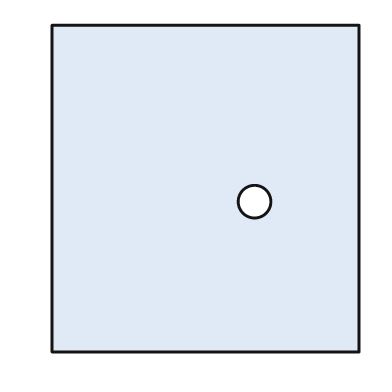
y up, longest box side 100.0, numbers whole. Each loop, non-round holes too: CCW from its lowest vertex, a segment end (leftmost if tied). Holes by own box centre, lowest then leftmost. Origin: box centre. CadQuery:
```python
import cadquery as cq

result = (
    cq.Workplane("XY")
    .moveTo(-47.0, -50.0)
    .lineTo(47.0, -50.0)
    .lineTo(47.0, 50.0)
    .lineTo(-47.0, 50.0)
    .close()
    .moveTo(15.0, -4.0)
    .circle(5.0)
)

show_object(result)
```